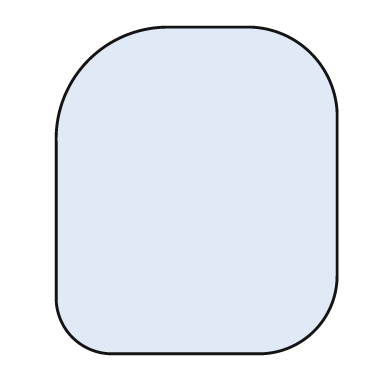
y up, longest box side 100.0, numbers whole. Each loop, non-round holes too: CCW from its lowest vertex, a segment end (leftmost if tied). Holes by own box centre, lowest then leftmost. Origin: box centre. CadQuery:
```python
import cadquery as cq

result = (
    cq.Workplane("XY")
    .moveTo(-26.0, -50.0)
    .lineTo(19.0, -50.0)
    .threePointArc((36.0, -43.0), (43.0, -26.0))
    .lineTo(43.0, 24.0)
    .threePointArc((35.0, 42.0), (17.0, 50.0))
    .lineTo(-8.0, 50.0)
    .threePointArc((-33.0, 40.0), (-43.0, 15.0))
    .lineTo(-43.0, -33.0)
    .threePointArc((-38.0, -45.0), (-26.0, -50.0))
    .close()
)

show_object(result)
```